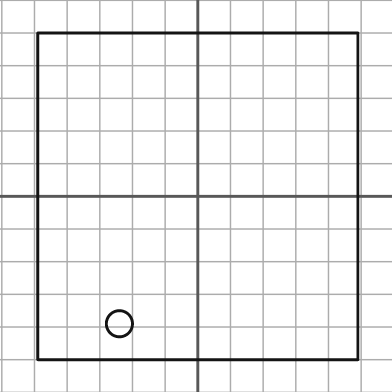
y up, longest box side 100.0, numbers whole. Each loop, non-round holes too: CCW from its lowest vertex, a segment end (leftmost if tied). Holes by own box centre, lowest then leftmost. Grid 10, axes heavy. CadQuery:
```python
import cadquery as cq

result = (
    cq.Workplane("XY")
    .moveTo(-49.0, -50.0)
    .lineTo(49.0, -50.0)
    .lineTo(49.0, 50.0)
    .lineTo(-49.0, 50.0)
    .close()
    .moveTo(-24.0, -39.0)
    .circle(4.0)
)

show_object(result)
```